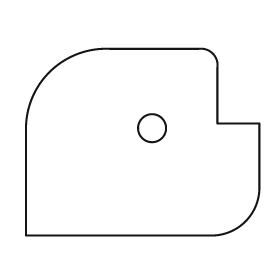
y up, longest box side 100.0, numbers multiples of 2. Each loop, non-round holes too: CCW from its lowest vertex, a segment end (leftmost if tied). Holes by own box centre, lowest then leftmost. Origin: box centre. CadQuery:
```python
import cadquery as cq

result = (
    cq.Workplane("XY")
    .moveTo(-50.0, -40.0)
    .lineTo(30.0, -40.0)
    .threePointArc((44.0, -34.0), (50.0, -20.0))
    .lineTo(50.0, 8.0)
    .lineTo(32.0, 8.0)
    .lineTo(32.0, 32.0)
    .threePointArc((30.0, 38.0), (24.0, 40.0))
    .lineTo(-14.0, 40.0)
    .threePointArc((-40.0, 30.0), (-50.0, 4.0))
    .close()
    .moveTo(4.0, 6.0)
    .circle(6.0)
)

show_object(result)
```